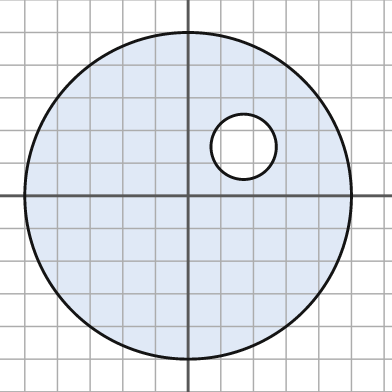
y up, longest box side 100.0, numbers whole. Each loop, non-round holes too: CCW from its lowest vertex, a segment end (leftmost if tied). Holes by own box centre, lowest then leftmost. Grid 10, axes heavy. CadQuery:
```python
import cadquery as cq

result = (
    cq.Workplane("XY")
    .moveTo(0.0, 0.0)
    .circle(50.0)
    .moveTo(17.0, 15.0)
    .circle(10.0)
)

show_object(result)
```